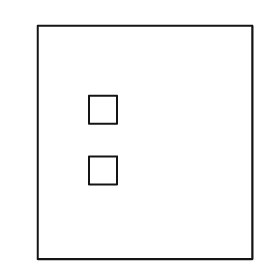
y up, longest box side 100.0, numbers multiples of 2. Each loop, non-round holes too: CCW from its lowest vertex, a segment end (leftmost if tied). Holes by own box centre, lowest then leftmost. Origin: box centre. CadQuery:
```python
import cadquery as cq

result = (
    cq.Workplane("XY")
    .moveTo(-46.0, -50.0)
    .lineTo(46.0, -50.0)
    .lineTo(46.0, 50.0)
    .lineTo(-46.0, 50.0)
    .close()
    .moveTo(-24.0, -18.0)
    .lineTo(-12.0, -18.0)
    .lineTo(-12.0, -6.0)
    .lineTo(-24.0, -6.0)
    .close()
    .moveTo(-24.0, 8.0)
    .lineTo(-12.0, 8.0)
    .lineTo(-12.0, 20.0)
    .lineTo(-24.0, 20.0)
    .close()
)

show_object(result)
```